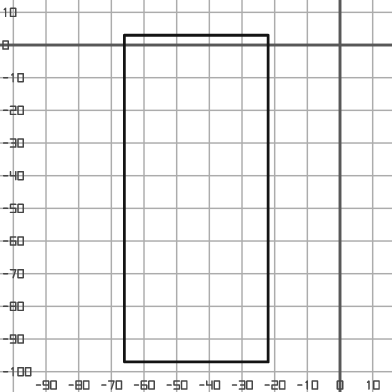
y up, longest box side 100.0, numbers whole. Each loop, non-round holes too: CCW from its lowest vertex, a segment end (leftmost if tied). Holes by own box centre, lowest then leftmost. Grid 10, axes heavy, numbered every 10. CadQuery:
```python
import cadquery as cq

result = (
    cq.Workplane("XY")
    .moveTo(-66.0, -97.0)
    .lineTo(-22.0, -97.0)
    .lineTo(-22.0, 3.0)
    .lineTo(-66.0, 3.0)
    .close()
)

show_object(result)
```